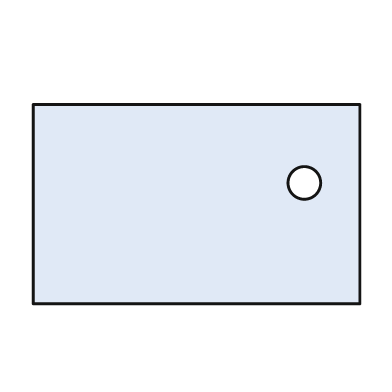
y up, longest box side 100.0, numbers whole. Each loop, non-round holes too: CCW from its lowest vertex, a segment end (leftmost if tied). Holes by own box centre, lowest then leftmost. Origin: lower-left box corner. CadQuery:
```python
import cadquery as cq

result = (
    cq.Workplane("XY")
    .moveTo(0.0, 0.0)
    .lineTo(100.0, 0.0)
    .lineTo(100.0, 61.0)
    .lineTo(0.0, 61.0)
    .close()
    .moveTo(83.0, 37.0)
    .circle(5.0)
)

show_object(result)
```